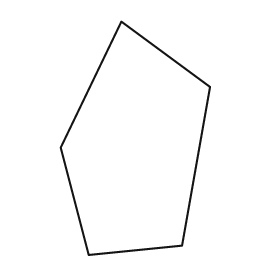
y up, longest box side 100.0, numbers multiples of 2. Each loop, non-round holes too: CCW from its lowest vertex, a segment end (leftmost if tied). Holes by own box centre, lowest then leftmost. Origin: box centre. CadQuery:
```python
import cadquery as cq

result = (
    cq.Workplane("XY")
    .moveTo(-20.0, -50.0)
    .lineTo(20.0, -46.0)
    .lineTo(32.0, 22.0)
    .lineTo(-6.0, 50.0)
    .lineTo(-32.0, -4.0)
    .close()
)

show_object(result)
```